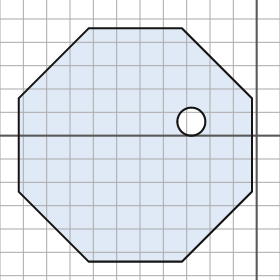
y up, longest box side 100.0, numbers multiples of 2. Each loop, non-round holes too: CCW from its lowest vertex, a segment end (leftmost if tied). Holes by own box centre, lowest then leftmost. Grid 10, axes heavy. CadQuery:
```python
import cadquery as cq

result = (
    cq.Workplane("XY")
    .moveTo(-72.0, -54.0)
    .lineTo(-32.0, -54.0)
    .lineTo(-2.0, -24.0)
    .lineTo(-2.0, 16.0)
    .lineTo(-32.0, 46.0)
    .lineTo(-72.0, 46.0)
    .lineTo(-102.0, 16.0)
    .lineTo(-102.0, -24.0)
    .close()
    .moveTo(-28.0, 6.0)
    .circle(6.0)
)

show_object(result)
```